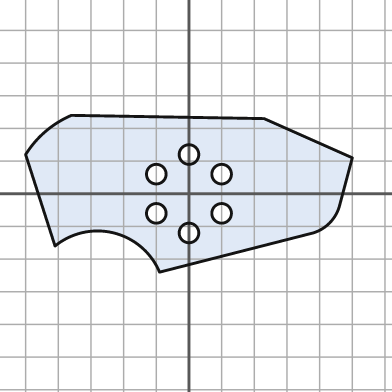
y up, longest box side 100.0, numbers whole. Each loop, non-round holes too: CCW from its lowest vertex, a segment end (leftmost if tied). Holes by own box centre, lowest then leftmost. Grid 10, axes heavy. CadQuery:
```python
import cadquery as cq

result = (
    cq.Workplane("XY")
    .moveTo(-9.0, -24.0)
    .lineTo(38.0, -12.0)
    .threePointArc((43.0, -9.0), (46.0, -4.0))
    .lineTo(50.0, 11.0)
    .lineTo(23.0, 23.0)
    .lineTo(-36.0, 24.0)
    .threePointArc((-44.0, 19.0), (-50.0, 12.0))
    .lineTo(-41.0, -16.0)
    .threePointArc((-23.0, -12.0), (-9.0, -24.0))
    .close()
    .moveTo(0.0, -12.0)
    .circle(3.0)
    .moveTo(-10.0, -6.0)
    .circle(3.0)
    .moveTo(10.0, -6.0)
    .circle(3.0)
    .moveTo(-10.0, 6.0)
    .circle(3.0)
    .moveTo(10.0, 6.0)
    .circle(3.0)
    .moveTo(0.0, 12.0)
    .circle(3.0)
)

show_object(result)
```